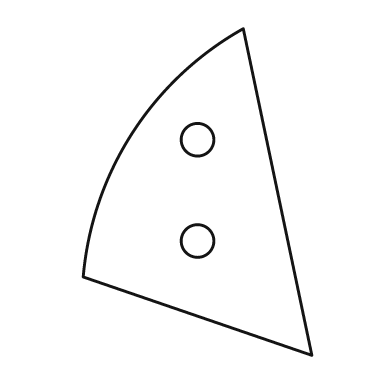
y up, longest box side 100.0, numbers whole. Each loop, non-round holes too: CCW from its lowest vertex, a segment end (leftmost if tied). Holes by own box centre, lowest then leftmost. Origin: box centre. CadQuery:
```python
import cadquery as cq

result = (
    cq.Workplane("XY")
    .moveTo(35.0, -50.0)
    .lineTo(14.0, 50.0)
    .threePointArc((-20.0, 18.0), (-35.0, -26.0))
    .close()
    .moveTo(0.0, -15.0)
    .circle(5.0)
    .moveTo(0.0, 16.0)
    .circle(5.0)
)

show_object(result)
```